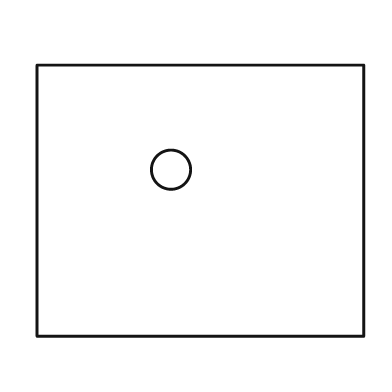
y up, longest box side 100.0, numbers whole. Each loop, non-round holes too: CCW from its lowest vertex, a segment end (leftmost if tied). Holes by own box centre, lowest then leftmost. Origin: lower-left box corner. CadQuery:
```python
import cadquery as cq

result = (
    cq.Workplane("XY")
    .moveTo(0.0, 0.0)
    .lineTo(100.0, 0.0)
    .lineTo(100.0, 83.0)
    .lineTo(0.0, 83.0)
    .close()
    .moveTo(41.0, 51.0)
    .circle(6.0)
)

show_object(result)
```